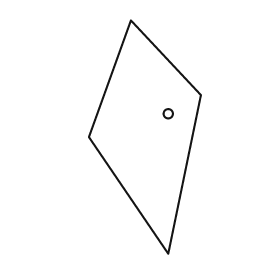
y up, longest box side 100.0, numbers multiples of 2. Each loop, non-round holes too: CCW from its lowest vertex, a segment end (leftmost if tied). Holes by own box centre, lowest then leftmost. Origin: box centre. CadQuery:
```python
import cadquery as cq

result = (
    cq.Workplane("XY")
    .moveTo(10.0, -50.0)
    .lineTo(24.0, 18.0)
    .lineTo(-6.0, 50.0)
    .lineTo(-24.0, 0.0)
    .close()
    .moveTo(10.0, 10.0)
    .circle(2.0)
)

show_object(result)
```